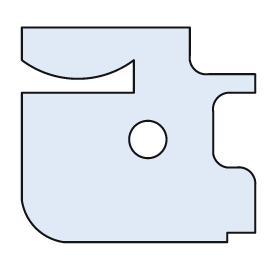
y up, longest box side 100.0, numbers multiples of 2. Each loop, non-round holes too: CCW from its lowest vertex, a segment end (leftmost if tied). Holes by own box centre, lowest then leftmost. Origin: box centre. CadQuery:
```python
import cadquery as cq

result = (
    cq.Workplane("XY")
    .moveTo(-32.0, -46.0)
    .lineTo(38.0, -46.0)
    .lineTo(38.0, -42.0)
    .lineTo(50.0, -42.0)
    .lineTo(50.0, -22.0)
    .threePointArc((48.0, -16.0), (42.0, -14.0))
    .lineTo(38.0, -14.0)
    .threePointArc((34.0, -12.0), (32.0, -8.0))
    .lineTo(32.0, 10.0)
    .threePointArc((34.0, 16.0), (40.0, 18.0))
    .lineTo(50.0, 18.0)
    .lineTo(50.0, 26.0)
    .lineTo(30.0, 26.0)
    .threePointArc((24.0, 28.0), (22.0, 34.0))
    .lineTo(22.0, 46.0)
    .lineTo(-50.0, 46.0)
    .lineTo(-50.0, 32.0)
    .threePointArc((-26.0, 24.0), (-2.0, 32.0))
    .lineTo(-2.0, 18.0)
    .lineTo(-50.0, 18.0)
    .lineTo(-50.0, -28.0)
    .threePointArc((-44.0, -40.0), (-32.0, -46.0))
    .close()
    .moveTo(4.0, -2.0)
    .circle(8.0)
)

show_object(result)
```